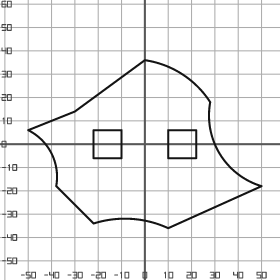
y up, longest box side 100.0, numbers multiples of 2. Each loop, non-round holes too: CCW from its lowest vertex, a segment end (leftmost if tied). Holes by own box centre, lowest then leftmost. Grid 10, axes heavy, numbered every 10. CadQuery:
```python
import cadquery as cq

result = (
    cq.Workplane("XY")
    .moveTo(10.0, -36.0)
    .lineTo(50.0, -18.0)
    .threePointArc((32.0, -4.0), (28.0, 18.0))
    .threePointArc((16.0, 30.0), (0.0, 36.0))
    .lineTo(-30.0, 14.0)
    .lineTo(-50.0, 6.0)
    .threePointArc((-40.0, -4.0), (-38.0, -18.0))
    .lineTo(-22.0, -34.0)
    .threePointArc((-6.0, -32.0), (10.0, -36.0))
    .close()
    .moveTo(-22.0, -6.0)
    .lineTo(-10.0, -6.0)
    .lineTo(-10.0, 6.0)
    .lineTo(-22.0, 6.0)
    .close()
    .moveTo(10.0, -6.0)
    .lineTo(22.0, -6.0)
    .lineTo(22.0, 6.0)
    .lineTo(10.0, 6.0)
    .close()
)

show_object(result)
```